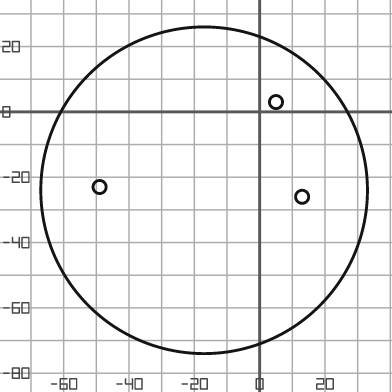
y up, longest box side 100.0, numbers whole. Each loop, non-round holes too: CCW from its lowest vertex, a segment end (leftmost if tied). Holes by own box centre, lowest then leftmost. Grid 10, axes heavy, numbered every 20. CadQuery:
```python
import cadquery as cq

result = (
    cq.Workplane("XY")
    .moveTo(-17.0, -24.0)
    .circle(50.0)
    .moveTo(13.0, -26.0)
    .circle(2.0)
    .moveTo(-49.0, -23.0)
    .circle(2.0)
    .moveTo(5.0, 3.0)
    .circle(2.0)
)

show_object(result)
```